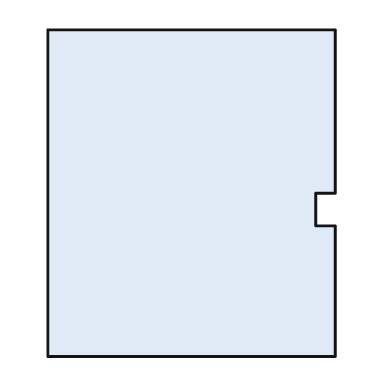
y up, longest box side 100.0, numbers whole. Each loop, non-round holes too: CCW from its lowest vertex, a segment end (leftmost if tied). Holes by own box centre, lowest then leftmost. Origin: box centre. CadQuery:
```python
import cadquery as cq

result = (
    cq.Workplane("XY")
    .moveTo(-44.0, -50.0)
    .lineTo(44.0, -50.0)
    .lineTo(44.0, -10.0)
    .lineTo(38.0, -10.0)
    .lineTo(38.0, 0.0)
    .lineTo(44.0, 0.0)
    .lineTo(44.0, 50.0)
    .lineTo(-44.0, 50.0)
    .close()
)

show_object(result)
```